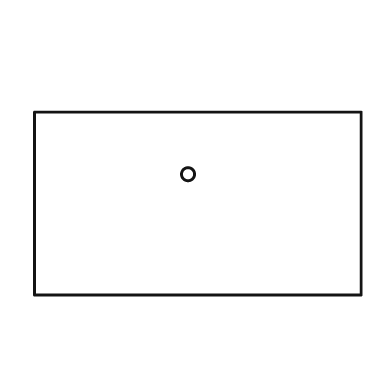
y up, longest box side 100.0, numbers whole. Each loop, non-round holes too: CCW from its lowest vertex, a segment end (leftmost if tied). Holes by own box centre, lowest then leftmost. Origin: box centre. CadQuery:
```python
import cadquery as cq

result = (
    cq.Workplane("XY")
    .moveTo(-50.0, -28.0)
    .lineTo(50.0, -28.0)
    .lineTo(50.0, 28.0)
    .lineTo(-50.0, 28.0)
    .close()
    .moveTo(-3.0, 9.0)
    .circle(2.0)
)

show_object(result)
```